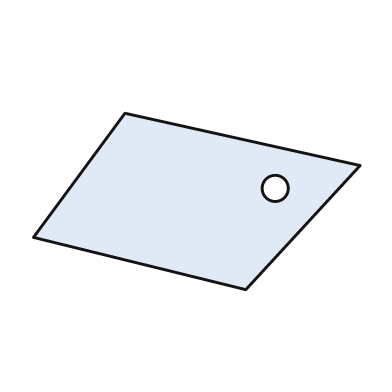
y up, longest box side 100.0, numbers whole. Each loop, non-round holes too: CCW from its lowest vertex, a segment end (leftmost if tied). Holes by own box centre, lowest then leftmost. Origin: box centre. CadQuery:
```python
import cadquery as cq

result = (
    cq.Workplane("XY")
    .moveTo(15.0, -27.0)
    .lineTo(50.0, 11.0)
    .lineTo(-22.0, 27.0)
    .lineTo(-50.0, -11.0)
    .close()
    .moveTo(24.0, 4.0)
    .circle(4.0)
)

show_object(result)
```